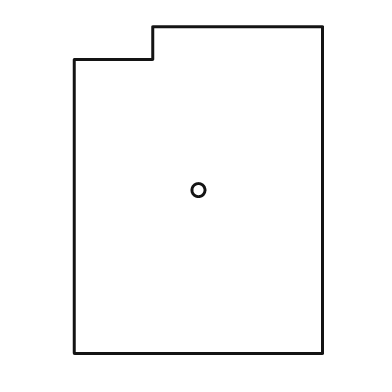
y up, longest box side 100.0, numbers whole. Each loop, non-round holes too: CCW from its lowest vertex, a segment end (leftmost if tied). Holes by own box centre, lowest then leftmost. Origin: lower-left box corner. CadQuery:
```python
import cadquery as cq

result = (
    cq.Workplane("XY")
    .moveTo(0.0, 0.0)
    .lineTo(76.0, 0.0)
    .lineTo(76.0, 100.0)
    .lineTo(24.0, 100.0)
    .lineTo(24.0, 90.0)
    .lineTo(0.0, 90.0)
    .close()
    .moveTo(38.0, 50.0)
    .circle(2.0)
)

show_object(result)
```